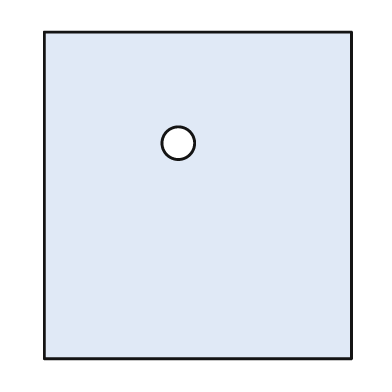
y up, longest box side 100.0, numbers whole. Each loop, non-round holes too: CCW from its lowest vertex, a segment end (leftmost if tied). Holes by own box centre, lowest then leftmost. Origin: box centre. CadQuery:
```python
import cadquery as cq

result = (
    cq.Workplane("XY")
    .moveTo(-47.0, -50.0)
    .lineTo(47.0, -50.0)
    .lineTo(47.0, 50.0)
    .lineTo(-47.0, 50.0)
    .close()
    .moveTo(-6.0, 16.0)
    .circle(5.0)
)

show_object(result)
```